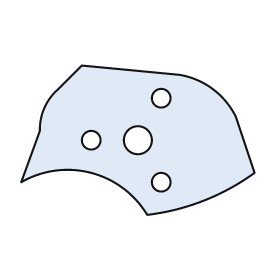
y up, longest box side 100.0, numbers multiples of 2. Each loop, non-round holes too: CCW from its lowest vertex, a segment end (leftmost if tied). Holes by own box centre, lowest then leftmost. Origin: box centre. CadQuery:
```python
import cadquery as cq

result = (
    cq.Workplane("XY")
    .moveTo(4.0, -32.0)
    .threePointArc((28.0, -26.0), (50.0, -14.0))
    .lineTo(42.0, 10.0)
    .threePointArc((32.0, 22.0), (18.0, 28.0))
    .lineTo(-24.0, 32.0)
    .lineTo(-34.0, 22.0)
    .threePointArc((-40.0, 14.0), (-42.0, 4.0))
    .lineTo(-50.0, -18.0)
    .threePointArc((-20.0, -14.0), (4.0, -32.0))
    .close()
    .moveTo(10.0, -18.0)
    .circle(4.0)
    .moveTo(-20.0, 0.0)
    .circle(4.0)
    .moveTo(0.0, 0.0)
    .circle(6.0)
    .moveTo(10.0, 18.0)
    .circle(4.0)
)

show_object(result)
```